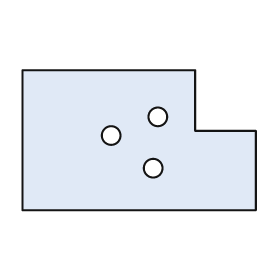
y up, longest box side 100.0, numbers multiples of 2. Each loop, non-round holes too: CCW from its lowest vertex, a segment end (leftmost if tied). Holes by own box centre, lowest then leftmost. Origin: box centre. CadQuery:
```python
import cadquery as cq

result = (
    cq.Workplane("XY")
    .moveTo(-50.0, -30.0)
    .lineTo(50.0, -30.0)
    .lineTo(50.0, 4.0)
    .lineTo(24.0, 4.0)
    .lineTo(24.0, 30.0)
    .lineTo(-50.0, 30.0)
    .close()
    .moveTo(6.0, -12.0)
    .circle(4.0)
    .moveTo(-12.0, 2.0)
    .circle(4.0)
    .moveTo(8.0, 10.0)
    .circle(4.0)
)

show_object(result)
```